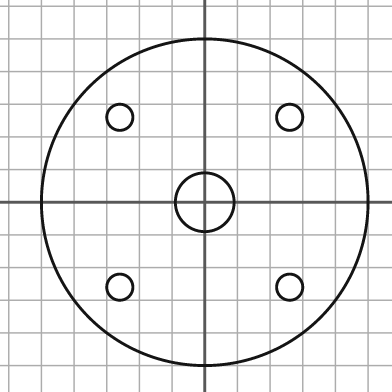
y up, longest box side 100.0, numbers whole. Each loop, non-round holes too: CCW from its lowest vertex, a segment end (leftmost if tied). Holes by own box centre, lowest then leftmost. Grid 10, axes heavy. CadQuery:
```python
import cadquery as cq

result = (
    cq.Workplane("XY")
    .moveTo(0.0, 0.0)
    .circle(50.0)
    .moveTo(-26.0, -26.0)
    .circle(4.0)
    .moveTo(26.0, -26.0)
    .circle(4.0)
    .moveTo(0.0, 0.0)
    .circle(9.0)
    .moveTo(-26.0, 26.0)
    .circle(4.0)
    .moveTo(26.0, 26.0)
    .circle(4.0)
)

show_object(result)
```